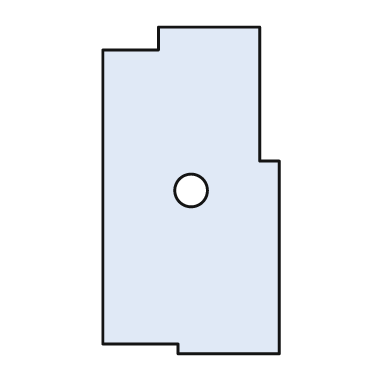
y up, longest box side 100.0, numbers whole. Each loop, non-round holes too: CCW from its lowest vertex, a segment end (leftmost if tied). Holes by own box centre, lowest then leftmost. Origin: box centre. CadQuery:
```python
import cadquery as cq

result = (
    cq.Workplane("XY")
    .moveTo(-4.0, -50.0)
    .lineTo(27.0, -50.0)
    .lineTo(27.0, 9.0)
    .lineTo(21.0, 9.0)
    .lineTo(21.0, 50.0)
    .lineTo(-10.0, 50.0)
    .lineTo(-10.0, 43.0)
    .lineTo(-27.0, 43.0)
    .lineTo(-27.0, -47.0)
    .lineTo(-4.0, -47.0)
    .close()
    .moveTo(0.0, 0.0)
    .circle(5.0)
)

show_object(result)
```